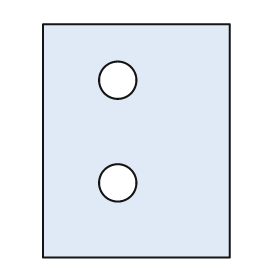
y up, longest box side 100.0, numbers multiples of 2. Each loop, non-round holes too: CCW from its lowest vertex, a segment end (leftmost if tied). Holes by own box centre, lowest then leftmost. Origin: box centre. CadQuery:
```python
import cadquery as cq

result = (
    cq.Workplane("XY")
    .moveTo(-40.0, -50.0)
    .lineTo(40.0, -50.0)
    .lineTo(40.0, 50.0)
    .lineTo(-40.0, 50.0)
    .close()
    .moveTo(-8.0, -18.0)
    .circle(8.0)
    .moveTo(-8.0, 26.0)
    .circle(8.0)
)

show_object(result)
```